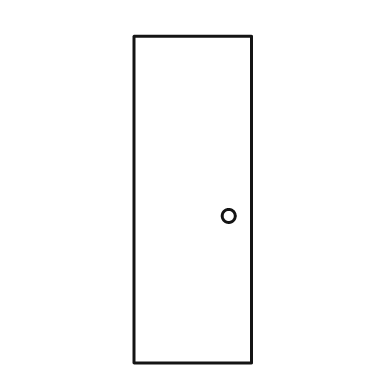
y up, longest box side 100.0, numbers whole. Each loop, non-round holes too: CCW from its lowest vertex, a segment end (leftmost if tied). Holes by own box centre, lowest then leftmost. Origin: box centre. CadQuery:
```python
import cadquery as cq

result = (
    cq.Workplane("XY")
    .moveTo(-18.0, -50.0)
    .lineTo(18.0, -50.0)
    .lineTo(18.0, 50.0)
    .lineTo(-18.0, 50.0)
    .close()
    .moveTo(11.0, -5.0)
    .circle(2.0)
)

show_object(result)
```